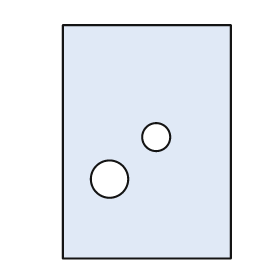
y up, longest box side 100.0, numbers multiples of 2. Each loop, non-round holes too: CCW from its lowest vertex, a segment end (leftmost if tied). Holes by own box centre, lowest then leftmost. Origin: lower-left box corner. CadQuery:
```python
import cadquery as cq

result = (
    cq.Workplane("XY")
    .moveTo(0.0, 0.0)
    .lineTo(72.0, 0.0)
    .lineTo(72.0, 100.0)
    .lineTo(0.0, 100.0)
    .close()
    .moveTo(20.0, 34.0)
    .circle(8.0)
    .moveTo(40.0, 52.0)
    .circle(6.0)
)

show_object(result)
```